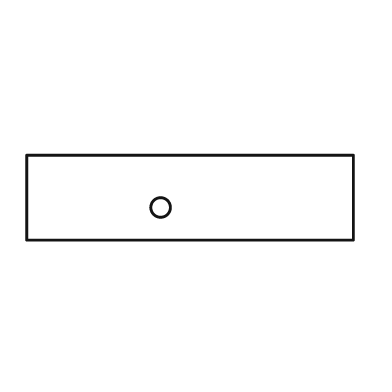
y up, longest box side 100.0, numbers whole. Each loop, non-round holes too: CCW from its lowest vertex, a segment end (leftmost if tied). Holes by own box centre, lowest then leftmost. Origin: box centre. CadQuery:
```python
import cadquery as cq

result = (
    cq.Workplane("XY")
    .moveTo(-50.0, -13.0)
    .lineTo(50.0, -13.0)
    .lineTo(50.0, 13.0)
    .lineTo(-50.0, 13.0)
    .close()
    .moveTo(-9.0, -3.0)
    .circle(3.0)
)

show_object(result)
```